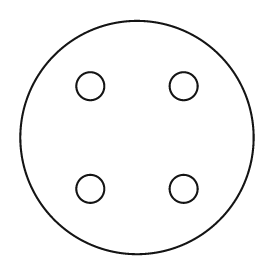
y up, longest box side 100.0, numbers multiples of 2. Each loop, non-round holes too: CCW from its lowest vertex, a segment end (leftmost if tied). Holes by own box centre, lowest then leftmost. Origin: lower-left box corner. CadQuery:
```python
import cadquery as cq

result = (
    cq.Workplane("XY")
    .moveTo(50.0, 50.0)
    .circle(50.0)
    .moveTo(30.0, 28.0)
    .circle(6.0)
    .moveTo(70.0, 28.0)
    .circle(6.0)
    .moveTo(30.0, 72.0)
    .circle(6.0)
    .moveTo(70.0, 72.0)
    .circle(6.0)
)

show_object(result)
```